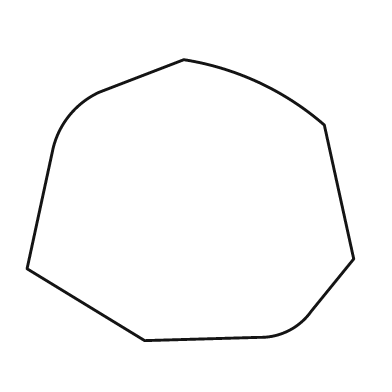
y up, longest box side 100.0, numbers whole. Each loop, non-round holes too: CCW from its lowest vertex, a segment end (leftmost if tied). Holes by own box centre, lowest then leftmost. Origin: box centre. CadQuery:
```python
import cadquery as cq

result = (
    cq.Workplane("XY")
    .moveTo(-14.0, -43.0)
    .lineTo(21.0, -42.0)
    .threePointArc((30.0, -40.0), (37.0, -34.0))
    .lineTo(50.0, -18.0)
    .lineTo(41.0, 23.0)
    .threePointArc((21.0, 36.0), (-2.0, 43.0))
    .lineTo(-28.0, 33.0)
    .threePointArc((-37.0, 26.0), (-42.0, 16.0))
    .lineTo(-50.0, -21.0)
    .close()
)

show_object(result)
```